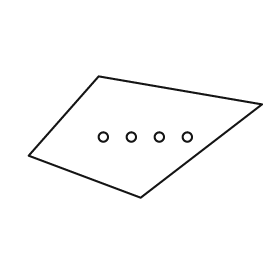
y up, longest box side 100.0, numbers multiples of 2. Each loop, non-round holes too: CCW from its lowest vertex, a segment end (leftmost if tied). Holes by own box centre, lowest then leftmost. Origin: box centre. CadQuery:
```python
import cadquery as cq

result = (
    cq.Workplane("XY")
    .moveTo(-2.0, -26.0)
    .lineTo(50.0, 14.0)
    .lineTo(-20.0, 26.0)
    .lineTo(-50.0, -8.0)
    .close()
    .moveTo(-18.0, 0.0)
    .circle(2.0)
    .moveTo(-6.0, 0.0)
    .circle(2.0)
    .moveTo(6.0, 0.0)
    .circle(2.0)
    .moveTo(18.0, 0.0)
    .circle(2.0)
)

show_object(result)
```